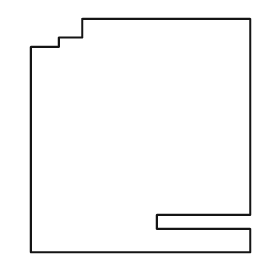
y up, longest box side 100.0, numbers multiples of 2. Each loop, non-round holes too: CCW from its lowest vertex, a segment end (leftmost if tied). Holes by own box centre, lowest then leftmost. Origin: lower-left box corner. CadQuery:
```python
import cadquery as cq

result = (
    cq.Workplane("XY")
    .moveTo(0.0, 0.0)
    .lineTo(94.0, 0.0)
    .lineTo(94.0, 10.0)
    .lineTo(54.0, 10.0)
    .lineTo(54.0, 16.0)
    .lineTo(94.0, 16.0)
    .lineTo(94.0, 100.0)
    .lineTo(22.0, 100.0)
    .lineTo(22.0, 92.0)
    .lineTo(12.0, 92.0)
    .lineTo(12.0, 88.0)
    .lineTo(0.0, 88.0)
    .close()
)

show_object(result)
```